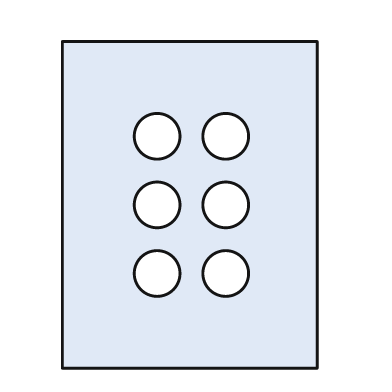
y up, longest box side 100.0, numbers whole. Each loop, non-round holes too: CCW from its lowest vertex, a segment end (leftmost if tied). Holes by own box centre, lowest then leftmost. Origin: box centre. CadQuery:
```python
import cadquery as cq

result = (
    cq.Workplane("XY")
    .moveTo(-39.0, -50.0)
    .lineTo(39.0, -50.0)
    .lineTo(39.0, 50.0)
    .lineTo(-39.0, 50.0)
    .close()
    .moveTo(-10.0, -21.0)
    .circle(7.0)
    .moveTo(11.0, -21.0)
    .circle(7.0)
    .moveTo(-10.0, 0.0)
    .circle(7.0)
    .moveTo(11.0, 0.0)
    .circle(7.0)
    .moveTo(-10.0, 21.0)
    .circle(7.0)
    .moveTo(11.0, 21.0)
    .circle(7.0)
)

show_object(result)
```